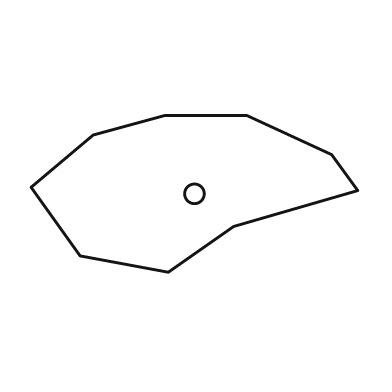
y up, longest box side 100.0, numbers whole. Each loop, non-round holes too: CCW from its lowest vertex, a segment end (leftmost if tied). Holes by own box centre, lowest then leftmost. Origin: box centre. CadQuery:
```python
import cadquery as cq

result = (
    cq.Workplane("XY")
    .moveTo(-8.0, -24.0)
    .lineTo(12.0, -10.0)
    .lineTo(50.0, 1.0)
    .lineTo(42.0, 12.0)
    .lineTo(16.0, 24.0)
    .lineTo(-9.0, 24.0)
    .lineTo(-31.0, 18.0)
    .lineTo(-50.0, 2.0)
    .lineTo(-35.0, -19.0)
    .close()
    .moveTo(0.0, 0.0)
    .circle(3.0)
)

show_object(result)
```